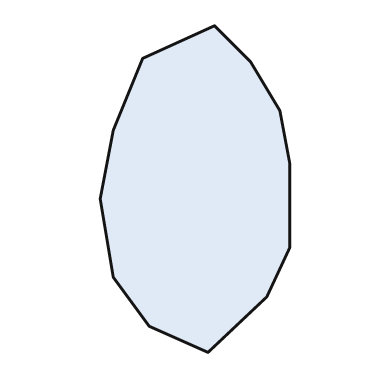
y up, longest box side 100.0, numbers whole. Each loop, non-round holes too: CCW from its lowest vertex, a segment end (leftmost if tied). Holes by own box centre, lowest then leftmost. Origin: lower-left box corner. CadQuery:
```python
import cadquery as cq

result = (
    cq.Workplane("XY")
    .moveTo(33.0, 0.0)
    .lineTo(51.0, 17.0)
    .lineTo(58.0, 32.0)
    .lineTo(58.0, 58.0)
    .lineTo(55.0, 74.0)
    .lineTo(46.0, 89.0)
    .lineTo(35.0, 100.0)
    .lineTo(13.0, 90.0)
    .lineTo(4.0, 68.0)
    .lineTo(0.0, 47.0)
    .lineTo(4.0, 23.0)
    .lineTo(15.0, 8.0)
    .close()
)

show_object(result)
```